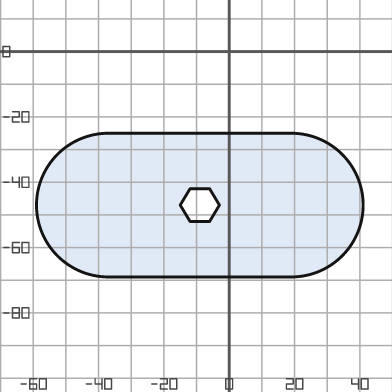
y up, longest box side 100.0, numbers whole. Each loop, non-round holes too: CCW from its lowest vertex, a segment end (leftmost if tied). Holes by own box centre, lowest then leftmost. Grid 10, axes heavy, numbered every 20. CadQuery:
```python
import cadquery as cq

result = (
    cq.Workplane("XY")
    .moveTo(-37.0, -69.0)
    .lineTo(19.0, -69.0)
    .threePointArc((41.0, -47.0), (19.0, -25.0))
    .lineTo(-37.0, -25.0)
    .threePointArc((-59.0, -47.0), (-37.0, -69.0))
    .close()
    .moveTo(-12.0, -52.0)
    .lineTo(-6.0, -52.0)
    .lineTo(-3.0, -47.0)
    .lineTo(-6.0, -42.0)
    .lineTo(-12.0, -42.0)
    .lineTo(-15.0, -47.0)
    .close()
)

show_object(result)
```